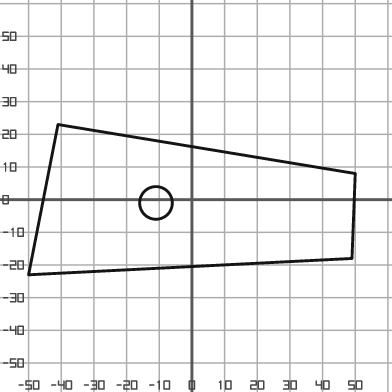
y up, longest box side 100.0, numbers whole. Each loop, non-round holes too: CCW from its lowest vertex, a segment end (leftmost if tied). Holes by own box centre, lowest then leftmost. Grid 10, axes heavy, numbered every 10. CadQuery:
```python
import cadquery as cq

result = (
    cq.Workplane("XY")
    .moveTo(-50.0, -23.0)
    .lineTo(49.0, -18.0)
    .lineTo(50.0, 8.0)
    .lineTo(-41.0, 23.0)
    .close()
    .moveTo(-11.0, -1.0)
    .circle(5.0)
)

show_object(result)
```